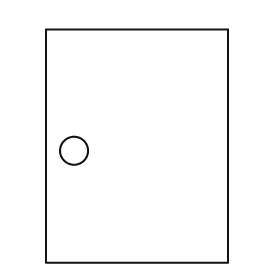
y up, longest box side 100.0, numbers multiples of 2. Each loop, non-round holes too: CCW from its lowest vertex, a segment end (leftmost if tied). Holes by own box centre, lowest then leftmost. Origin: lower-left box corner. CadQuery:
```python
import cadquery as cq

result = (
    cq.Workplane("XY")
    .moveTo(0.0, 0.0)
    .lineTo(78.0, 0.0)
    .lineTo(78.0, 100.0)
    .lineTo(0.0, 100.0)
    .close()
    .moveTo(12.0, 48.0)
    .circle(6.0)
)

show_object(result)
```